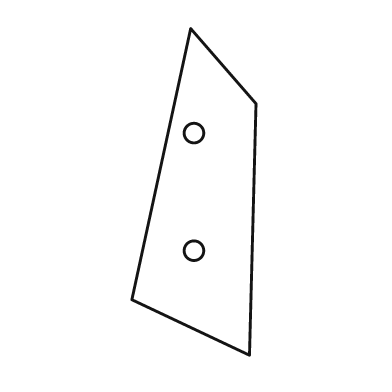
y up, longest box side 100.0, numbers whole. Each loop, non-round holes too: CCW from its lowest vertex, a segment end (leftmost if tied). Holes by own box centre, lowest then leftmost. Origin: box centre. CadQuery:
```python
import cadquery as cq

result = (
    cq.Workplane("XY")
    .moveTo(17.0, -50.0)
    .lineTo(19.0, 27.0)
    .lineTo(-1.0, 50.0)
    .lineTo(-19.0, -33.0)
    .close()
    .moveTo(0.0, -18.0)
    .circle(3.0)
    .moveTo(0.0, 18.0)
    .circle(3.0)
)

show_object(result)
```